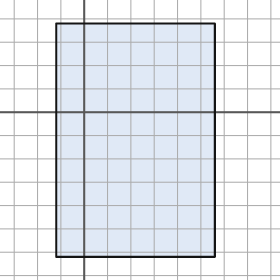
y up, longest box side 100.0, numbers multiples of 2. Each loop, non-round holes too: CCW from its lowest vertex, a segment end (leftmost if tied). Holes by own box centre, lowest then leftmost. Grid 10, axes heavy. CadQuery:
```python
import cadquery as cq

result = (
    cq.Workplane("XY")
    .moveTo(-12.0, -62.0)
    .lineTo(56.0, -62.0)
    .lineTo(56.0, 38.0)
    .lineTo(-12.0, 38.0)
    .close()
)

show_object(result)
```